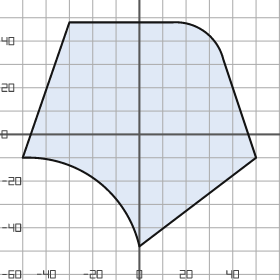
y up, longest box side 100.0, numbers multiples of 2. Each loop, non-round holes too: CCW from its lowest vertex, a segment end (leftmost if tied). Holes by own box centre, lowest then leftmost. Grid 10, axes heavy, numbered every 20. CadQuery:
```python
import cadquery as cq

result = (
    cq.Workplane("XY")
    .moveTo(0.0, -48.0)
    .lineTo(50.0, -10.0)
    .lineTo(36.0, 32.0)
    .threePointArc((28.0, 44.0), (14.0, 48.0))
    .lineTo(-30.0, 48.0)
    .lineTo(-50.0, -10.0)
    .threePointArc((-18.0, -20.0), (0.0, -48.0))
    .close()
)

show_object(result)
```